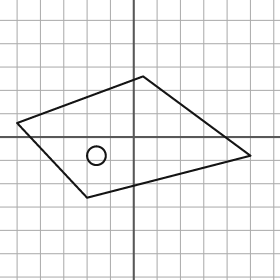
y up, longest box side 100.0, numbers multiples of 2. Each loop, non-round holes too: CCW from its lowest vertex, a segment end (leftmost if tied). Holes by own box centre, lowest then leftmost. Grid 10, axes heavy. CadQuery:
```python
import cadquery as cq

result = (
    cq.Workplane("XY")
    .moveTo(-20.0, -26.0)
    .lineTo(50.0, -8.0)
    .lineTo(4.0, 26.0)
    .lineTo(-50.0, 6.0)
    .close()
    .moveTo(-16.0, -8.0)
    .circle(4.0)
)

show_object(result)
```